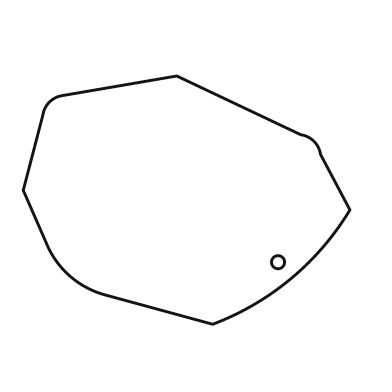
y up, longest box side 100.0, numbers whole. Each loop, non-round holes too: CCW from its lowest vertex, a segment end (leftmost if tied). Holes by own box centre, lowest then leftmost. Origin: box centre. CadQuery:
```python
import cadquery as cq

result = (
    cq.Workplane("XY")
    .moveTo(8.0, -38.0)
    .threePointArc((32.0, -24.0), (50.0, -3.0))
    .lineTo(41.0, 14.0)
    .threePointArc((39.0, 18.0), (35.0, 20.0))
    .lineTo(-3.0, 38.0)
    .lineTo(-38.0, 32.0)
    .threePointArc((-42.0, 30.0), (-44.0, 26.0))
    .lineTo(-50.0, 3.0)
    .lineTo(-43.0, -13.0)
    .threePointArc((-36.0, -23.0), (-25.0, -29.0))
    .close()
    .moveTo(28.0, -19.0)
    .circle(2.0)
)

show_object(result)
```